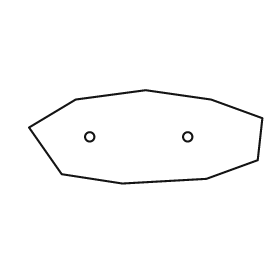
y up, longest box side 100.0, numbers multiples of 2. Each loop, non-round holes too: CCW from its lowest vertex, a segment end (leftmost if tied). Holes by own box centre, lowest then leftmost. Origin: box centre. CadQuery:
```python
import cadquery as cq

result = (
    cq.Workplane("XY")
    .moveTo(-10.0, -20.0)
    .lineTo(26.0, -18.0)
    .lineTo(48.0, -10.0)
    .lineTo(50.0, 8.0)
    .lineTo(28.0, 16.0)
    .lineTo(0.0, 20.0)
    .lineTo(-30.0, 16.0)
    .lineTo(-50.0, 4.0)
    .lineTo(-36.0, -16.0)
    .close()
    .moveTo(-24.0, 0.0)
    .circle(2.0)
    .moveTo(18.0, 0.0)
    .circle(2.0)
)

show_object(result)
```